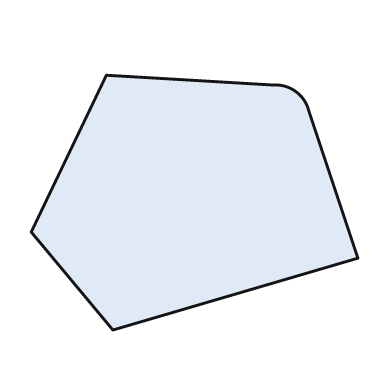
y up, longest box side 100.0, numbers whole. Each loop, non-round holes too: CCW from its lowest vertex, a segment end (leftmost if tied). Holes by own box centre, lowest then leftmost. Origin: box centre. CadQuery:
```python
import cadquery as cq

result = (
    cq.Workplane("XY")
    .moveTo(-25.0, -39.0)
    .lineTo(50.0, -17.0)
    .lineTo(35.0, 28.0)
    .threePointArc((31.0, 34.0), (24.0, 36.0))
    .lineTo(-27.0, 39.0)
    .lineTo(-50.0, -9.0)
    .close()
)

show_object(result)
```